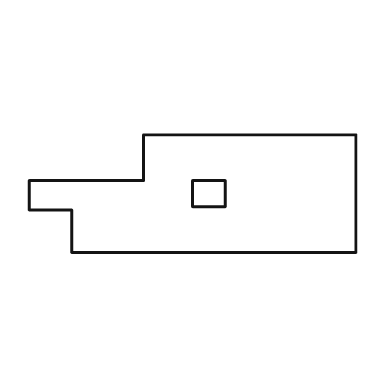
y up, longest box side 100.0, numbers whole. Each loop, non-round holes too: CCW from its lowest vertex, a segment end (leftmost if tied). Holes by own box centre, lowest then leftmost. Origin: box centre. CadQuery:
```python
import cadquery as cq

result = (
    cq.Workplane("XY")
    .moveTo(-37.0, -18.0)
    .lineTo(50.0, -18.0)
    .lineTo(50.0, 18.0)
    .lineTo(-15.0, 18.0)
    .lineTo(-15.0, 4.0)
    .lineTo(-50.0, 4.0)
    .lineTo(-50.0, -5.0)
    .lineTo(-37.0, -5.0)
    .close()
    .moveTo(0.0, -4.0)
    .lineTo(10.0, -4.0)
    .lineTo(10.0, 4.0)
    .lineTo(0.0, 4.0)
    .close()
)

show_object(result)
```